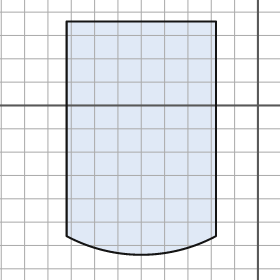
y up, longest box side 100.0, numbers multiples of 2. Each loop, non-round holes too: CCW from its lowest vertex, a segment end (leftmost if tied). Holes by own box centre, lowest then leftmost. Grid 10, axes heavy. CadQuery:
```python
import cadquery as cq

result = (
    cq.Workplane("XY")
    .moveTo(-82.0, -56.0)
    .threePointArc((-50.0, -64.0), (-18.0, -56.0))
    .lineTo(-18.0, 36.0)
    .lineTo(-82.0, 36.0)
    .close()
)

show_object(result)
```